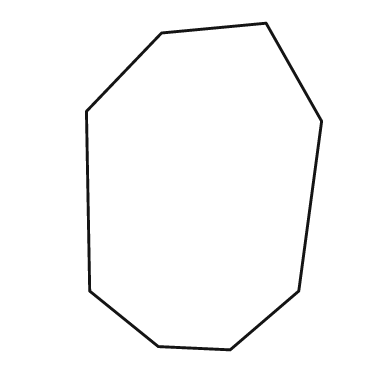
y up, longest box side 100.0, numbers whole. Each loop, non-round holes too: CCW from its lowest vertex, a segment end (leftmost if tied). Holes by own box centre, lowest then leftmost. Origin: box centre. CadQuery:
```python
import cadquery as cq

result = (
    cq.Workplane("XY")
    .moveTo(8.0, -50.0)
    .lineTo(29.0, -32.0)
    .lineTo(36.0, 20.0)
    .lineTo(19.0, 50.0)
    .lineTo(-13.0, 47.0)
    .lineTo(-36.0, 23.0)
    .lineTo(-35.0, -32.0)
    .lineTo(-14.0, -49.0)
    .close()
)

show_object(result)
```